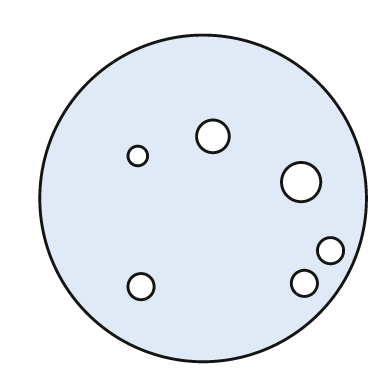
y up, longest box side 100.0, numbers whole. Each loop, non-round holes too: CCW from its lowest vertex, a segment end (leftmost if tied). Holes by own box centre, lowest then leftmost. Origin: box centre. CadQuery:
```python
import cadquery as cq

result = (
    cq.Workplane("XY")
    .moveTo(0.0, 0.0)
    .circle(50.0)
    .moveTo(-19.0, -27.0)
    .circle(4.0)
    .moveTo(31.0, -26.0)
    .circle(4.0)
    .moveTo(39.0, -16.0)
    .circle(4.0)
    .moveTo(30.0, 5.0)
    .circle(6.0)
    .moveTo(-20.0, 13.0)
    .circle(3.0)
    .moveTo(3.0, 19.0)
    .circle(5.0)
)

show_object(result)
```